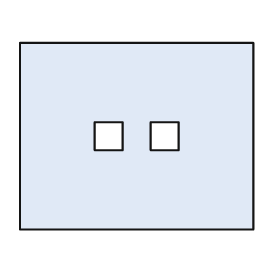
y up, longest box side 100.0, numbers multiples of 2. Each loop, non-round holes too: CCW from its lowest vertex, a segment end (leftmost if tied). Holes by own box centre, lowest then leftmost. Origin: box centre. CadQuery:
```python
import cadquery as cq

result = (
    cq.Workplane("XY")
    .moveTo(-50.0, -40.0)
    .lineTo(50.0, -40.0)
    .lineTo(50.0, 40.0)
    .lineTo(-50.0, 40.0)
    .close()
    .moveTo(-18.0, -6.0)
    .lineTo(-6.0, -6.0)
    .lineTo(-6.0, 6.0)
    .lineTo(-18.0, 6.0)
    .close()
    .moveTo(6.0, -6.0)
    .lineTo(18.0, -6.0)
    .lineTo(18.0, 6.0)
    .lineTo(6.0, 6.0)
    .close()
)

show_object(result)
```